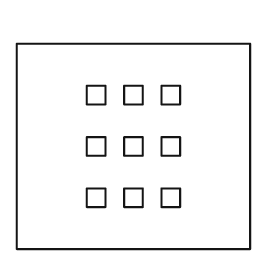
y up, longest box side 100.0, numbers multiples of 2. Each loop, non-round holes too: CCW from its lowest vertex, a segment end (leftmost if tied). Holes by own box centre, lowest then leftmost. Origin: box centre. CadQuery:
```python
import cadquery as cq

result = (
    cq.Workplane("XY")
    .moveTo(-50.0, -44.0)
    .lineTo(50.0, -44.0)
    .lineTo(50.0, 44.0)
    .lineTo(-50.0, 44.0)
    .close()
    .moveTo(-20.0, -26.0)
    .lineTo(-12.0, -26.0)
    .lineTo(-12.0, -18.0)
    .lineTo(-20.0, -18.0)
    .close()
    .moveTo(-4.0, -26.0)
    .lineTo(4.0, -26.0)
    .lineTo(4.0, -18.0)
    .lineTo(-4.0, -18.0)
    .close()
    .moveTo(12.0, -26.0)
    .lineTo(20.0, -26.0)
    .lineTo(20.0, -18.0)
    .lineTo(12.0, -18.0)
    .close()
    .moveTo(-20.0, -4.0)
    .lineTo(-12.0, -4.0)
    .lineTo(-12.0, 4.0)
    .lineTo(-20.0, 4.0)
    .close()
    .moveTo(-4.0, -4.0)
    .lineTo(4.0, -4.0)
    .lineTo(4.0, 4.0)
    .lineTo(-4.0, 4.0)
    .close()
    .moveTo(12.0, -4.0)
    .lineTo(20.0, -4.0)
    .lineTo(20.0, 4.0)
    .lineTo(12.0, 4.0)
    .close()
    .moveTo(-20.0, 18.0)
    .lineTo(-12.0, 18.0)
    .lineTo(-12.0, 26.0)
    .lineTo(-20.0, 26.0)
    .close()
    .moveTo(-4.0, 18.0)
    .lineTo(4.0, 18.0)
    .lineTo(4.0, 26.0)
    .lineTo(-4.0, 26.0)
    .close()
    .moveTo(12.0, 18.0)
    .lineTo(20.0, 18.0)
    .lineTo(20.0, 26.0)
    .lineTo(12.0, 26.0)
    .close()
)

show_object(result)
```